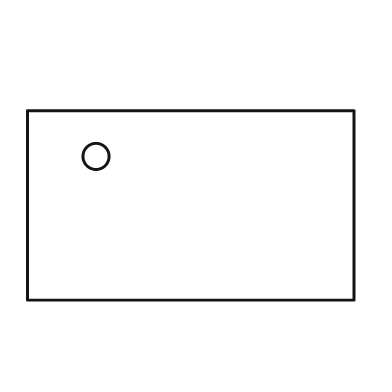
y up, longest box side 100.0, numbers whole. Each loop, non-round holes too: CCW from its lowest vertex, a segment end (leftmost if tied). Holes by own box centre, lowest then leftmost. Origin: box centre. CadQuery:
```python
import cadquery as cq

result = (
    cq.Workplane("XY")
    .moveTo(-50.0, -29.0)
    .lineTo(50.0, -29.0)
    .lineTo(50.0, 29.0)
    .lineTo(-50.0, 29.0)
    .close()
    .moveTo(-29.0, 15.0)
    .circle(4.0)
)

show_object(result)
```